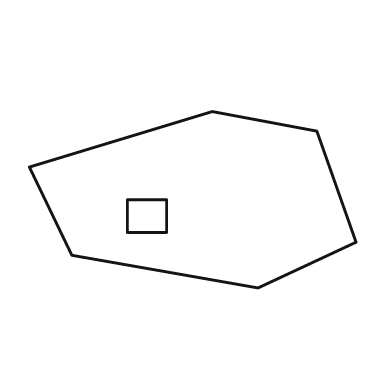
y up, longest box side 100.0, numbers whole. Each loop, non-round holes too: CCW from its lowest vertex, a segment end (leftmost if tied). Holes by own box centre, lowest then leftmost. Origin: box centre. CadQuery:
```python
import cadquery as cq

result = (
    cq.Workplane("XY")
    .moveTo(20.0, -27.0)
    .lineTo(50.0, -13.0)
    .lineTo(38.0, 21.0)
    .lineTo(6.0, 27.0)
    .lineTo(-50.0, 10.0)
    .lineTo(-37.0, -17.0)
    .close()
    .moveTo(-20.0, -10.0)
    .lineTo(-8.0, -10.0)
    .lineTo(-8.0, 0.0)
    .lineTo(-20.0, 0.0)
    .close()
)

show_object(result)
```